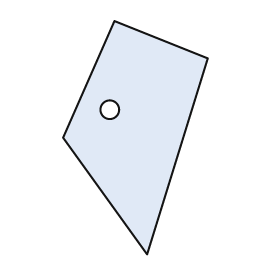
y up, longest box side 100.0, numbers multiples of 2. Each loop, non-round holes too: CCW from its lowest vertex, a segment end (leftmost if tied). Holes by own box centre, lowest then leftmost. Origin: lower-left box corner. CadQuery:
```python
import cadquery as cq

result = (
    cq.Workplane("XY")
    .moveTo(36.0, 0.0)
    .lineTo(62.0, 84.0)
    .lineTo(22.0, 100.0)
    .lineTo(0.0, 50.0)
    .close()
    .moveTo(20.0, 62.0)
    .circle(4.0)
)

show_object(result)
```